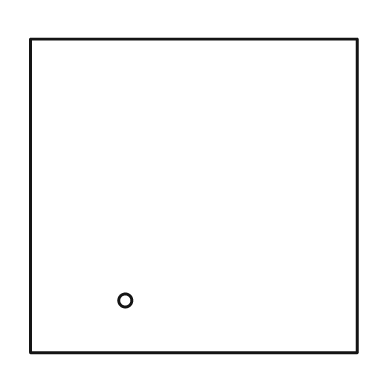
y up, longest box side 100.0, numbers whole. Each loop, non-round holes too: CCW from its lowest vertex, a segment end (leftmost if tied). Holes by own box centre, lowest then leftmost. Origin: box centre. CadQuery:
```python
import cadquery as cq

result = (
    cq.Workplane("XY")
    .moveTo(-50.0, -48.0)
    .lineTo(50.0, -48.0)
    .lineTo(50.0, 48.0)
    .lineTo(-50.0, 48.0)
    .close()
    .moveTo(-21.0, -32.0)
    .circle(2.0)
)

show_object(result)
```